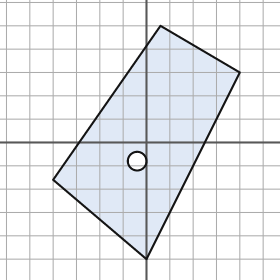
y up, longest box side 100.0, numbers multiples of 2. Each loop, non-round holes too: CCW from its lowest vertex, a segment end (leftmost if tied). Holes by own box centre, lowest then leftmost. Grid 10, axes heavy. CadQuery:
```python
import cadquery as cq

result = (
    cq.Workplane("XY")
    .moveTo(0.0, -50.0)
    .lineTo(40.0, 30.0)
    .lineTo(6.0, 50.0)
    .lineTo(-40.0, -16.0)
    .close()
    .moveTo(-4.0, -8.0)
    .circle(4.0)
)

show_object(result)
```